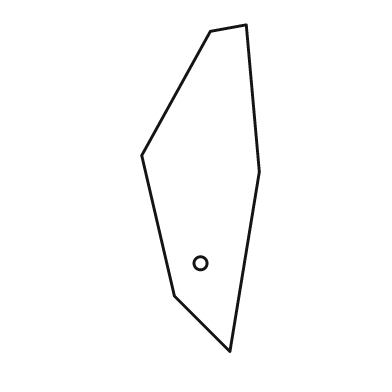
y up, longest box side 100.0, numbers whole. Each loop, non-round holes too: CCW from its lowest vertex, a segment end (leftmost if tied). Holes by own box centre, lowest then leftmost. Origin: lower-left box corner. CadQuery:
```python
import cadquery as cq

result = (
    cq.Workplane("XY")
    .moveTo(27.0, 0.0)
    .lineTo(36.0, 55.0)
    .lineTo(32.0, 100.0)
    .lineTo(21.0, 98.0)
    .lineTo(0.0, 60.0)
    .lineTo(10.0, 17.0)
    .close()
    .moveTo(18.0, 27.0)
    .circle(2.0)
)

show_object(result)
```